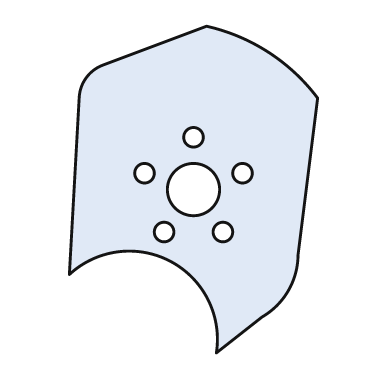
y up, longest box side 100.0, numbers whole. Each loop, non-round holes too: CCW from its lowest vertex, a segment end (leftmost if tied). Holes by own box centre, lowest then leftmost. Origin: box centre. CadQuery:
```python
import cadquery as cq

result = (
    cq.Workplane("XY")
    .moveTo(7.0, -50.0)
    .lineTo(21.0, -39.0)
    .threePointArc((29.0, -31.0), (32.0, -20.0))
    .lineTo(38.0, 28.0)
    .threePointArc((23.0, 42.0), (4.0, 50.0))
    .lineTo(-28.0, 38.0)
    .threePointArc((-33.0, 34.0), (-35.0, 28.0))
    .lineTo(-38.0, -26.0)
    .threePointArc((-7.0, -22.0), (7.0, -50.0))
    .close()
    .moveTo(-9.0, -13.0)
    .circle(3.0)
    .moveTo(9.0, -13.0)
    .circle(3.0)
    .moveTo(0.0, 0.0)
    .circle(8.0)
    .moveTo(-15.0, 5.0)
    .circle(3.0)
    .moveTo(15.0, 5.0)
    .circle(3.0)
    .moveTo(0.0, 16.0)
    .circle(3.0)
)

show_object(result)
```